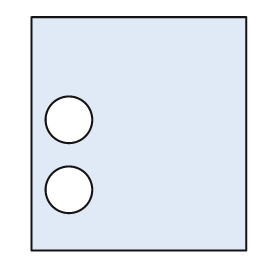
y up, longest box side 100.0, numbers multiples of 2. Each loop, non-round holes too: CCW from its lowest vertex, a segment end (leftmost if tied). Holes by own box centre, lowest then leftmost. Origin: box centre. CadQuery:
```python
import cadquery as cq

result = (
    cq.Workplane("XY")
    .moveTo(-46.0, -50.0)
    .lineTo(46.0, -50.0)
    .lineTo(46.0, 50.0)
    .lineTo(-46.0, 50.0)
    .close()
    .moveTo(-30.0, -24.0)
    .circle(10.0)
    .moveTo(-30.0, 6.0)
    .circle(10.0)
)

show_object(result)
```